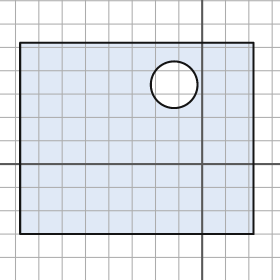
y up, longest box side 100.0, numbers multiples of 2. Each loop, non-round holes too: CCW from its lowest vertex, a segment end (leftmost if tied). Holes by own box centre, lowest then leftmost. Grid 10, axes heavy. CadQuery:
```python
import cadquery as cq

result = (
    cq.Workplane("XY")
    .moveTo(-78.0, -30.0)
    .lineTo(22.0, -30.0)
    .lineTo(22.0, 52.0)
    .lineTo(-78.0, 52.0)
    .close()
    .moveTo(-12.0, 34.0)
    .circle(10.0)
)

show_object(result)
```